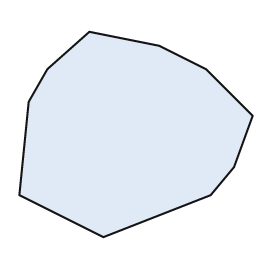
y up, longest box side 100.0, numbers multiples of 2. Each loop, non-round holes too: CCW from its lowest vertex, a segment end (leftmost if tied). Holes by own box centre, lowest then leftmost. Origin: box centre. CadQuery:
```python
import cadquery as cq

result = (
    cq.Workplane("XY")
    .moveTo(-14.0, -44.0)
    .lineTo(32.0, -26.0)
    .lineTo(42.0, -14.0)
    .lineTo(50.0, 8.0)
    .lineTo(30.0, 28.0)
    .lineTo(10.0, 38.0)
    .lineTo(-20.0, 44.0)
    .lineTo(-38.0, 28.0)
    .lineTo(-46.0, 14.0)
    .lineTo(-50.0, -26.0)
    .close()
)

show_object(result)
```